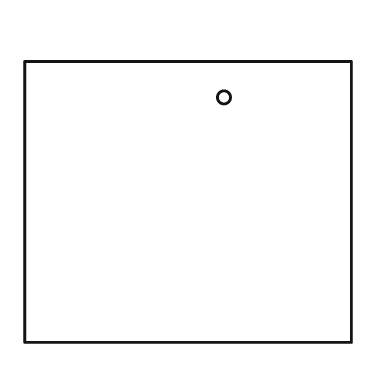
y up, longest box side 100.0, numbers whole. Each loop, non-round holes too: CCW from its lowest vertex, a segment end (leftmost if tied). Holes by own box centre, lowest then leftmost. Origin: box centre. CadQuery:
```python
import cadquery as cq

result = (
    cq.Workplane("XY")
    .moveTo(-50.0, -43.0)
    .lineTo(50.0, -43.0)
    .lineTo(50.0, 43.0)
    .lineTo(-50.0, 43.0)
    .close()
    .moveTo(11.0, 32.0)
    .circle(2.0)
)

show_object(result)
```